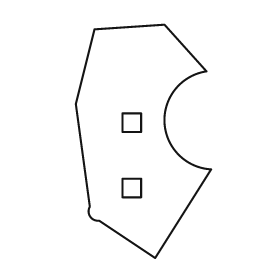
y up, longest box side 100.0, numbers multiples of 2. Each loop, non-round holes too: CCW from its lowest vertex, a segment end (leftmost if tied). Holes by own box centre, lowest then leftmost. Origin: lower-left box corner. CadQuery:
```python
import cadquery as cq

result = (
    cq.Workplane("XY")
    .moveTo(34.0, 0.0)
    .lineTo(58.0, 38.0)
    .threePointArc((38.0, 58.0), (56.0, 80.0))
    .lineTo(38.0, 100.0)
    .lineTo(8.0, 98.0)
    .lineTo(0.0, 66.0)
    .lineTo(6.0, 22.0)
    .threePointArc((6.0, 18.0), (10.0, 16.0))
    .close()
    .moveTo(20.0, 26.0)
    .lineTo(28.0, 26.0)
    .lineTo(28.0, 34.0)
    .lineTo(20.0, 34.0)
    .close()
    .moveTo(20.0, 54.0)
    .lineTo(28.0, 54.0)
    .lineTo(28.0, 62.0)
    .lineTo(20.0, 62.0)
    .close()
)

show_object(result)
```